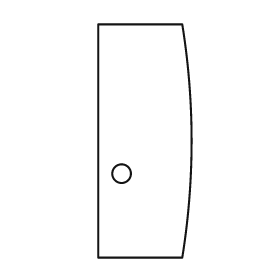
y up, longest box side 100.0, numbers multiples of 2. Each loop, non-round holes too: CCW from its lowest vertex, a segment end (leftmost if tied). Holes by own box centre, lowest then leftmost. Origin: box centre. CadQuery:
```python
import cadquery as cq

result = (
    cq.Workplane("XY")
    .moveTo(-20.0, -50.0)
    .lineTo(16.0, -50.0)
    .threePointArc((20.0, 0.0), (16.0, 50.0))
    .lineTo(-20.0, 50.0)
    .close()
    .moveTo(-10.0, -14.0)
    .circle(4.0)
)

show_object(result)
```